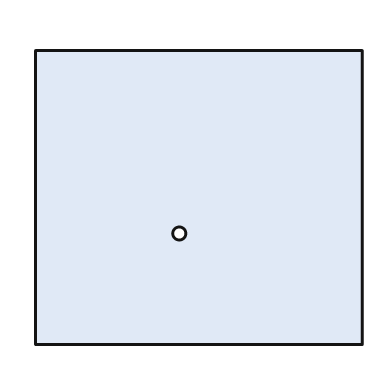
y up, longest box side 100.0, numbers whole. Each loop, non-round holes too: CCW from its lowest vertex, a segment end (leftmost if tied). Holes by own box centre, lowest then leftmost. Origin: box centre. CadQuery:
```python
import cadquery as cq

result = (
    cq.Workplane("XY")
    .moveTo(-50.0, -45.0)
    .lineTo(50.0, -45.0)
    .lineTo(50.0, 45.0)
    .lineTo(-50.0, 45.0)
    .close()
    .moveTo(-6.0, -11.0)
    .circle(2.0)
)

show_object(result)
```